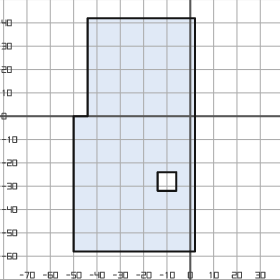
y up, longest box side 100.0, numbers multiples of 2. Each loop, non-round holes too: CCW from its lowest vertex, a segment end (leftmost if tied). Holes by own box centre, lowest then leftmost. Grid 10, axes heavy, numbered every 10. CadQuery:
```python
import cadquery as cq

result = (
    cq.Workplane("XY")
    .moveTo(-50.0, -58.0)
    .lineTo(2.0, -58.0)
    .lineTo(2.0, 42.0)
    .lineTo(-44.0, 42.0)
    .lineTo(-44.0, 0.0)
    .lineTo(-50.0, 0.0)
    .close()
    .moveTo(-14.0, -32.0)
    .lineTo(-6.0, -32.0)
    .lineTo(-6.0, -24.0)
    .lineTo(-14.0, -24.0)
    .close()
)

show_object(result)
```